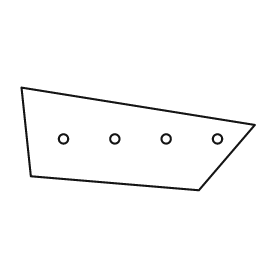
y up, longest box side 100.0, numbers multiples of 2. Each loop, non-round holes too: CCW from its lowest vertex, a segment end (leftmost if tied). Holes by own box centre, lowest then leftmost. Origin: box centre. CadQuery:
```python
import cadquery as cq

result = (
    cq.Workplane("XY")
    .moveTo(26.0, -22.0)
    .lineTo(50.0, 6.0)
    .lineTo(-50.0, 22.0)
    .lineTo(-46.0, -16.0)
    .close()
    .moveTo(-32.0, 0.0)
    .circle(2.0)
    .moveTo(-10.0, 0.0)
    .circle(2.0)
    .moveTo(12.0, 0.0)
    .circle(2.0)
    .moveTo(34.0, 0.0)
    .circle(2.0)
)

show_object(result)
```